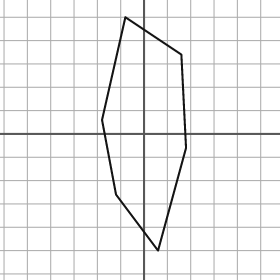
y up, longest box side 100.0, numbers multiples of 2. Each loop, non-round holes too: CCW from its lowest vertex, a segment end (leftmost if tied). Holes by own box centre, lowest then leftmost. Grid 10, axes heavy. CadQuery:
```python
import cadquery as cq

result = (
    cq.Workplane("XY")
    .moveTo(6.0, -50.0)
    .lineTo(18.0, -6.0)
    .lineTo(16.0, 34.0)
    .lineTo(-8.0, 50.0)
    .lineTo(-18.0, 6.0)
    .lineTo(-12.0, -26.0)
    .close()
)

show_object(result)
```